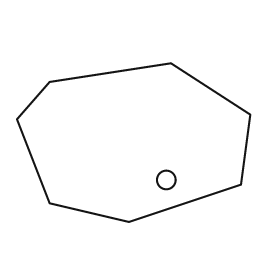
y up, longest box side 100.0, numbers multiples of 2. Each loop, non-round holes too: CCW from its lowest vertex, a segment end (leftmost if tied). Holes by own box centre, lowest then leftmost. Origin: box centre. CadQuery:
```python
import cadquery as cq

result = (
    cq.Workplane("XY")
    .moveTo(-2.0, -34.0)
    .lineTo(46.0, -18.0)
    .lineTo(50.0, 12.0)
    .lineTo(16.0, 34.0)
    .lineTo(-36.0, 26.0)
    .lineTo(-50.0, 10.0)
    .lineTo(-36.0, -26.0)
    .close()
    .moveTo(14.0, -16.0)
    .circle(4.0)
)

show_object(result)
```